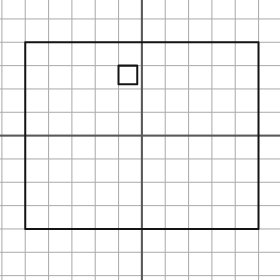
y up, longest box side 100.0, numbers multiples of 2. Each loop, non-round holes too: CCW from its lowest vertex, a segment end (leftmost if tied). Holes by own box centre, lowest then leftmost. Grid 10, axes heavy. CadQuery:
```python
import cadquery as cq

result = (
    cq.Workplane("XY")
    .moveTo(-50.0, -40.0)
    .lineTo(50.0, -40.0)
    .lineTo(50.0, 40.0)
    .lineTo(-50.0, 40.0)
    .close()
    .moveTo(-10.0, 22.0)
    .lineTo(-2.0, 22.0)
    .lineTo(-2.0, 30.0)
    .lineTo(-10.0, 30.0)
    .close()
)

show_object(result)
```